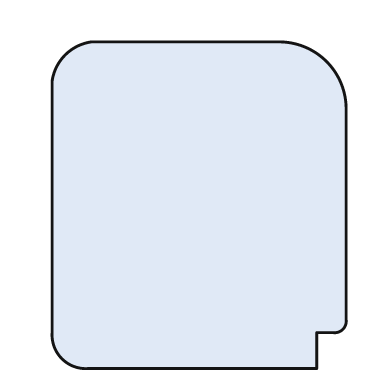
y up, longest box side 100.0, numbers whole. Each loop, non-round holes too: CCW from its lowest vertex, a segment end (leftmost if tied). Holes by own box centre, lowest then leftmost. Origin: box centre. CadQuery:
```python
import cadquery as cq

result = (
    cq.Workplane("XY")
    .moveTo(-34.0, -50.0)
    .lineTo(36.0, -50.0)
    .lineTo(36.0, -39.0)
    .lineTo(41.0, -39.0)
    .threePointArc((44.0, -38.0), (45.0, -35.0))
    .lineTo(45.0, 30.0)
    .threePointArc((39.0, 44.0), (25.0, 50.0))
    .lineTo(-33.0, 50.0)
    .threePointArc((-41.0, 46.0), (-45.0, 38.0))
    .lineTo(-45.0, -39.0)
    .threePointArc((-42.0, -47.0), (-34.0, -50.0))
    .close()
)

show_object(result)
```